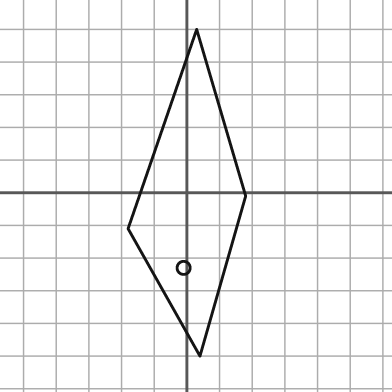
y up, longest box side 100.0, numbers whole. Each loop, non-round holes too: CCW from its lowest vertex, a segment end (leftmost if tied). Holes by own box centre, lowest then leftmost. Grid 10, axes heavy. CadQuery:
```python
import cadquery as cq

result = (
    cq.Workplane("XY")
    .moveTo(4.0, -50.0)
    .lineTo(18.0, -1.0)
    .lineTo(3.0, 50.0)
    .lineTo(-18.0, -11.0)
    .close()
    .moveTo(-1.0, -23.0)
    .circle(2.0)
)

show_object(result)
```